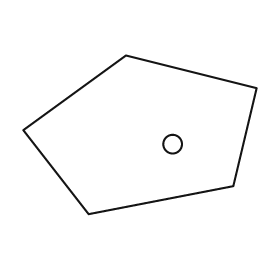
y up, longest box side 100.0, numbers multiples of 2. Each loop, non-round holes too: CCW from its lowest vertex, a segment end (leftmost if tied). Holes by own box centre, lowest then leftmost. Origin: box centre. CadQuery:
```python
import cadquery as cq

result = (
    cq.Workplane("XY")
    .moveTo(-22.0, -34.0)
    .lineTo(40.0, -22.0)
    .lineTo(50.0, 20.0)
    .lineTo(-6.0, 34.0)
    .lineTo(-50.0, 2.0)
    .close()
    .moveTo(14.0, -4.0)
    .circle(4.0)
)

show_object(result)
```